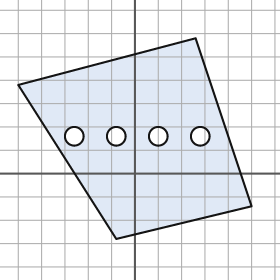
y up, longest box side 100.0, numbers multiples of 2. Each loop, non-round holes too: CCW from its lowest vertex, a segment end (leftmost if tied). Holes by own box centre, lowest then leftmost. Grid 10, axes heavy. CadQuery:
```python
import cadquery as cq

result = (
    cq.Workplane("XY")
    .moveTo(-8.0, -28.0)
    .lineTo(50.0, -14.0)
    .lineTo(26.0, 58.0)
    .lineTo(-50.0, 38.0)
    .close()
    .moveTo(-26.0, 16.0)
    .circle(4.0)
    .moveTo(-8.0, 16.0)
    .circle(4.0)
    .moveTo(10.0, 16.0)
    .circle(4.0)
    .moveTo(28.0, 16.0)
    .circle(4.0)
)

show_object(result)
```